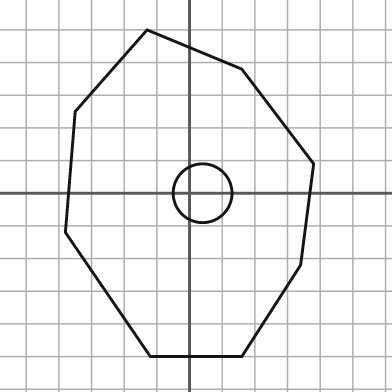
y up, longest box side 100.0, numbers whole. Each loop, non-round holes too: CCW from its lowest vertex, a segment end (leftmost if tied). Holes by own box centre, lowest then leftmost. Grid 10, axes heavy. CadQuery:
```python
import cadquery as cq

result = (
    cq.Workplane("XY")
    .moveTo(-12.0, -50.0)
    .lineTo(16.0, -50.0)
    .lineTo(34.0, -22.0)
    .lineTo(38.0, 9.0)
    .lineTo(16.0, 38.0)
    .lineTo(-13.0, 50.0)
    .lineTo(-35.0, 25.0)
    .lineTo(-38.0, -12.0)
    .close()
    .moveTo(4.0, 0.0)
    .circle(9.0)
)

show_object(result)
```